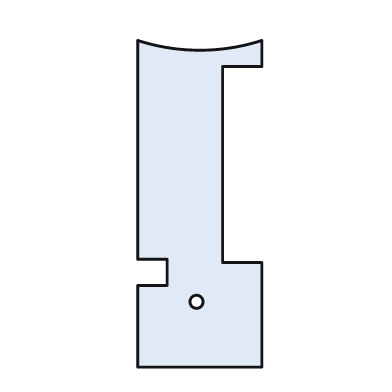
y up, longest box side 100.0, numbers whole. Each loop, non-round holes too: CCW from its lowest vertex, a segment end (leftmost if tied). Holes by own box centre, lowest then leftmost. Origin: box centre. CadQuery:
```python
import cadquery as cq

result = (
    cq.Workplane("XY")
    .moveTo(-19.0, -50.0)
    .lineTo(19.0, -50.0)
    .lineTo(19.0, -18.0)
    .lineTo(7.0, -18.0)
    .lineTo(7.0, 42.0)
    .lineTo(19.0, 42.0)
    .lineTo(19.0, 50.0)
    .threePointArc((0.0, 47.0), (-19.0, 50.0))
    .lineTo(-19.0, -17.0)
    .lineTo(-10.0, -17.0)
    .lineTo(-10.0, -25.0)
    .lineTo(-19.0, -25.0)
    .close()
    .moveTo(-1.0, -30.0)
    .circle(2.0)
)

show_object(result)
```